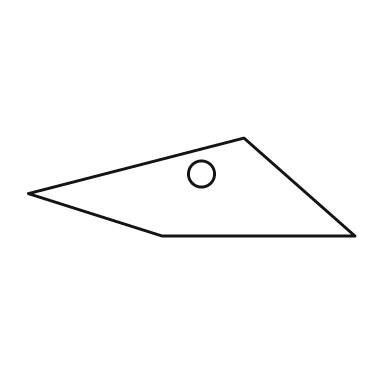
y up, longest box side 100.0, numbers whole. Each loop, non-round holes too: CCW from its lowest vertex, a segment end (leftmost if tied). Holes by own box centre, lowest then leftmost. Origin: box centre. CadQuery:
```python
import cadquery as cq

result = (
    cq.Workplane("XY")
    .moveTo(-9.0, -15.0)
    .lineTo(50.0, -15.0)
    .lineTo(16.0, 15.0)
    .lineTo(-50.0, -2.0)
    .close()
    .moveTo(3.0, 4.0)
    .circle(4.0)
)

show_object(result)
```